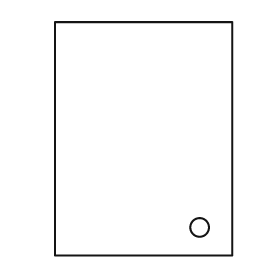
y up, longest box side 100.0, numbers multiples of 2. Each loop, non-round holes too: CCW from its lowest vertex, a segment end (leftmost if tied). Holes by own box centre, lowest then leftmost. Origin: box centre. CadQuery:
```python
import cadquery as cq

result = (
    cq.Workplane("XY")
    .moveTo(-38.0, -50.0)
    .lineTo(38.0, -50.0)
    .lineTo(38.0, 50.0)
    .lineTo(-38.0, 50.0)
    .close()
    .moveTo(24.0, -38.0)
    .circle(4.0)
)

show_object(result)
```